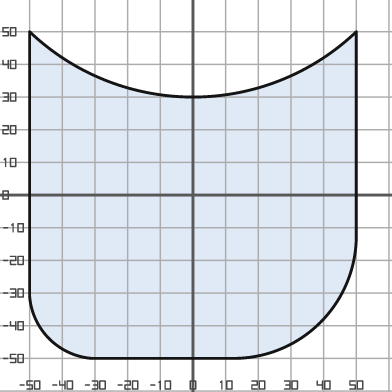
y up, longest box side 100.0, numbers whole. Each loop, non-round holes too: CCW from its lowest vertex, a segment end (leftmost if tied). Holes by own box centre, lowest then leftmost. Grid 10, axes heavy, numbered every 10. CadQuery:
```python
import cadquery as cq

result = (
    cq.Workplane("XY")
    .moveTo(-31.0, -50.0)
    .lineTo(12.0, -50.0)
    .threePointArc((39.0, -39.0), (50.0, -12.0))
    .lineTo(50.0, 50.0)
    .threePointArc((0.0, 30.0), (-50.0, 50.0))
    .lineTo(-50.0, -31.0)
    .threePointArc((-44.0, -44.0), (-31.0, -50.0))
    .close()
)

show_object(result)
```